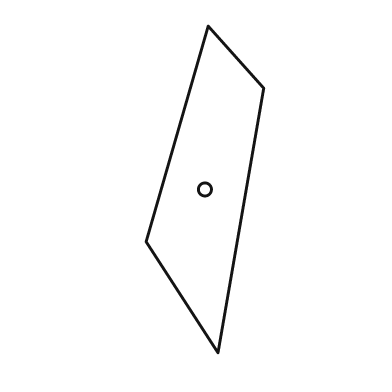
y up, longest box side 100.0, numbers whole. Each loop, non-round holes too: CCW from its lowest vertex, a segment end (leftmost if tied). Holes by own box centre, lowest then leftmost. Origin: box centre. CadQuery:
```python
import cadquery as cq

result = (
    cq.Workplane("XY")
    .moveTo(4.0, -50.0)
    .lineTo(18.0, 31.0)
    .lineTo(1.0, 50.0)
    .lineTo(-18.0, -16.0)
    .close()
    .moveTo(0.0, 0.0)
    .circle(2.0)
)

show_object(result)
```